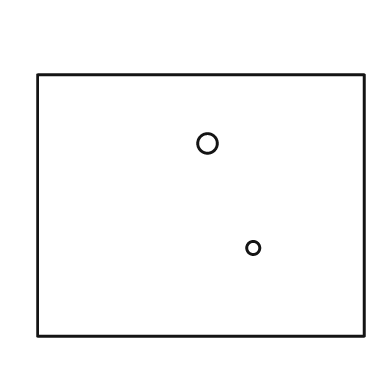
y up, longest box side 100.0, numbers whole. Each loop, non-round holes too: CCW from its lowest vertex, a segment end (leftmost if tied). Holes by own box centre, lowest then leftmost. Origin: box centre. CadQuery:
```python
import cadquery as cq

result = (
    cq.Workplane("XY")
    .moveTo(-50.0, -40.0)
    .lineTo(50.0, -40.0)
    .lineTo(50.0, 40.0)
    .lineTo(-50.0, 40.0)
    .close()
    .moveTo(16.0, -13.0)
    .circle(2.0)
    .moveTo(2.0, 19.0)
    .circle(3.0)
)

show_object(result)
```